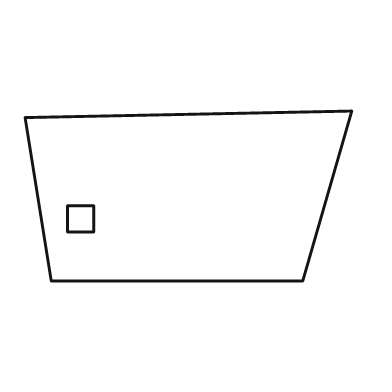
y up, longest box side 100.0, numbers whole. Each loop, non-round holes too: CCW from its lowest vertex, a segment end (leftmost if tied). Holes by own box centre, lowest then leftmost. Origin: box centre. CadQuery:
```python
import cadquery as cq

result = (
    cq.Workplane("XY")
    .moveTo(-42.0, -26.0)
    .lineTo(35.0, -26.0)
    .lineTo(50.0, 26.0)
    .lineTo(-50.0, 24.0)
    .close()
    .moveTo(-37.0, -11.0)
    .lineTo(-29.0, -11.0)
    .lineTo(-29.0, -3.0)
    .lineTo(-37.0, -3.0)
    .close()
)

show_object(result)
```